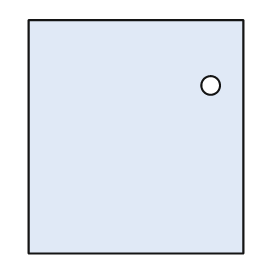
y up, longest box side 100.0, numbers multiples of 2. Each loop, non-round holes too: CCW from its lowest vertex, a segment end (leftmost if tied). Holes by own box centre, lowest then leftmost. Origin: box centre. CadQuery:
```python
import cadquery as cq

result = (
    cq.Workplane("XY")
    .moveTo(-46.0, -50.0)
    .lineTo(46.0, -50.0)
    .lineTo(46.0, 50.0)
    .lineTo(-46.0, 50.0)
    .close()
    .moveTo(32.0, 22.0)
    .circle(4.0)
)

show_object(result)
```